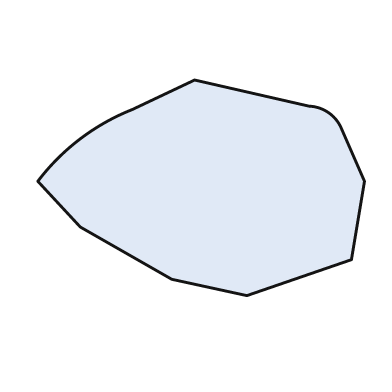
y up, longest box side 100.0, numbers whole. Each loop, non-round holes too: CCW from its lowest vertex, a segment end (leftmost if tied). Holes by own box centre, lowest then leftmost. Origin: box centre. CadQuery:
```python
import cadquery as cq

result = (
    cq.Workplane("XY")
    .moveTo(14.0, -33.0)
    .lineTo(46.0, -22.0)
    .lineTo(50.0, 2.0)
    .lineTo(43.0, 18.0)
    .threePointArc((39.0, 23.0), (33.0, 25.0))
    .lineTo(-2.0, 33.0)
    .lineTo(-21.0, 24.0)
    .threePointArc((-37.0, 15.0), (-50.0, 2.0))
    .lineTo(-37.0, -12.0)
    .lineTo(-9.0, -28.0)
    .close()
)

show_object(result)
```